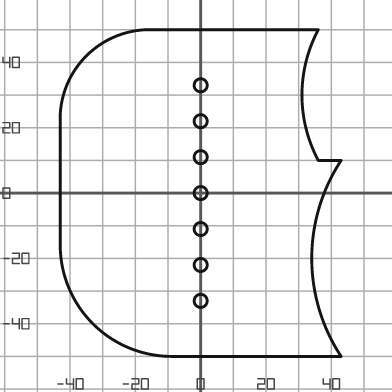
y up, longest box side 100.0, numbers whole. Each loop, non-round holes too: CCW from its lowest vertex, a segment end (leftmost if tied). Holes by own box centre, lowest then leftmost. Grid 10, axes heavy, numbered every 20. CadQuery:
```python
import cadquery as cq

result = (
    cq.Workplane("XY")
    .moveTo(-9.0, -50.0)
    .lineTo(43.0, -50.0)
    .threePointArc((34.0, -20.0), (43.0, 10.0))
    .lineTo(36.0, 10.0)
    .threePointArc((31.0, 30.0), (36.0, 50.0))
    .lineTo(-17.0, 50.0)
    .threePointArc((-35.0, 42.0), (-43.0, 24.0))
    .lineTo(-43.0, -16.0)
    .threePointArc((-33.0, -40.0), (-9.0, -50.0))
    .close()
    .moveTo(0.0, -33.0)
    .circle(2.0)
    .moveTo(0.0, -22.0)
    .circle(2.0)
    .moveTo(0.0, -11.0)
    .circle(2.0)
    .moveTo(0.0, 0.0)
    .circle(2.0)
    .moveTo(0.0, 11.0)
    .circle(2.0)
    .moveTo(0.0, 22.0)
    .circle(2.0)
    .moveTo(0.0, 33.0)
    .circle(2.0)
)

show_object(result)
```